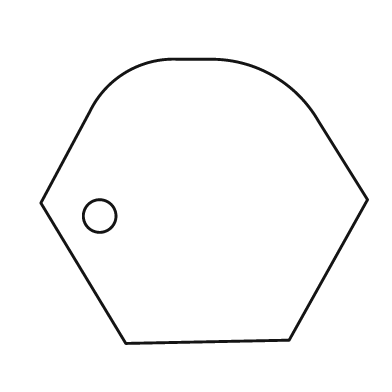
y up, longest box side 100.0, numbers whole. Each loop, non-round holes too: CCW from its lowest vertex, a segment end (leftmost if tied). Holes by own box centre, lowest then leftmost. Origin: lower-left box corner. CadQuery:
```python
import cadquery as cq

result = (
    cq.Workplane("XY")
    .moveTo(26.0, 0.0)
    .lineTo(76.0, 1.0)
    .lineTo(100.0, 44.0)
    .lineTo(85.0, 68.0)
    .threePointArc((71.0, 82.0), (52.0, 87.0))
    .lineTo(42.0, 87.0)
    .threePointArc((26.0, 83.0), (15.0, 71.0))
    .lineTo(0.0, 43.0)
    .close()
    .moveTo(18.0, 39.0)
    .circle(5.0)
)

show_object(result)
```